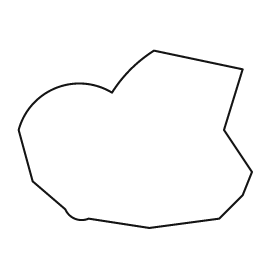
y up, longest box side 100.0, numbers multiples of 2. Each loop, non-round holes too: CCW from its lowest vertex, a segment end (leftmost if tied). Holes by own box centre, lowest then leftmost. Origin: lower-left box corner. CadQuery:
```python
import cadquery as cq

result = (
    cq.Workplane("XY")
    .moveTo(56.0, 0.0)
    .lineTo(86.0, 4.0)
    .lineTo(96.0, 14.0)
    .lineTo(100.0, 24.0)
    .lineTo(88.0, 42.0)
    .lineTo(96.0, 68.0)
    .lineTo(58.0, 76.0)
    .threePointArc((48.0, 68.0), (40.0, 58.0))
    .threePointArc((16.0, 60.0), (0.0, 42.0))
    .lineTo(6.0, 20.0)
    .lineTo(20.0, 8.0)
    .threePointArc((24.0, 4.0), (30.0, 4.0))
    .close()
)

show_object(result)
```